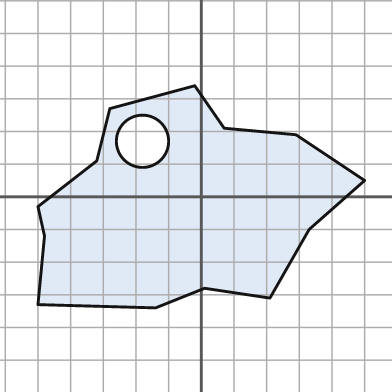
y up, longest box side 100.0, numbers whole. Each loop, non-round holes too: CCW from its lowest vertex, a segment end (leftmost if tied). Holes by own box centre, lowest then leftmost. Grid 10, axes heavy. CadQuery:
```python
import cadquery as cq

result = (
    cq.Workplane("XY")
    .moveTo(-14.0, -34.0)
    .lineTo(1.0, -28.0)
    .lineTo(21.0, -31.0)
    .lineTo(33.0, -10.0)
    .lineTo(50.0, 5.0)
    .lineTo(29.0, 19.0)
    .lineTo(7.0, 21.0)
    .lineTo(-2.0, 34.0)
    .lineTo(-28.0, 27.0)
    .lineTo(-32.0, 11.0)
    .lineTo(-50.0, -3.0)
    .lineTo(-48.0, -12.0)
    .lineTo(-50.0, -33.0)
    .close()
    .moveTo(-18.0, 17.0)
    .circle(8.0)
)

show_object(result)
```